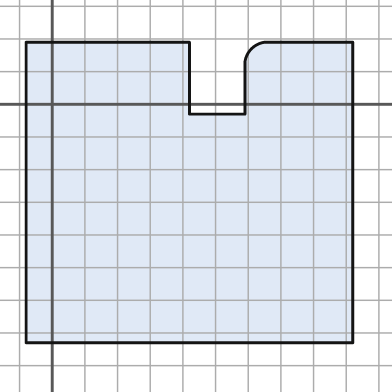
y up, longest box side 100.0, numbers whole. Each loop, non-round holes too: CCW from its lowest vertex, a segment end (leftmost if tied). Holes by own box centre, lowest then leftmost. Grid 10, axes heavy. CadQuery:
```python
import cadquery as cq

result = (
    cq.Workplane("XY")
    .moveTo(-8.0, -73.0)
    .lineTo(92.0, -73.0)
    .lineTo(92.0, 19.0)
    .lineTo(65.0, 19.0)
    .threePointArc((61.0, 17.0), (59.0, 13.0))
    .lineTo(59.0, -3.0)
    .lineTo(42.0, -3.0)
    .lineTo(42.0, 19.0)
    .lineTo(-8.0, 19.0)
    .close()
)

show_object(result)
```